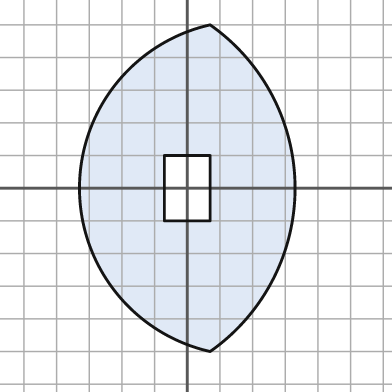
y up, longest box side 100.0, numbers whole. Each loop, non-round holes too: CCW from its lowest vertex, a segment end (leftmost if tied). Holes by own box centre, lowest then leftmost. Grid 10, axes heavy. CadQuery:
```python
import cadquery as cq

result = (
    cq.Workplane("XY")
    .moveTo(7.0, -50.0)
    .threePointArc((33.0, 0.0), (7.0, 50.0))
    .threePointArc((-33.0, 0.0), (7.0, -50.0))
    .close()
    .moveTo(-7.0, -10.0)
    .lineTo(7.0, -10.0)
    .lineTo(7.0, 10.0)
    .lineTo(-7.0, 10.0)
    .close()
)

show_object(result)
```